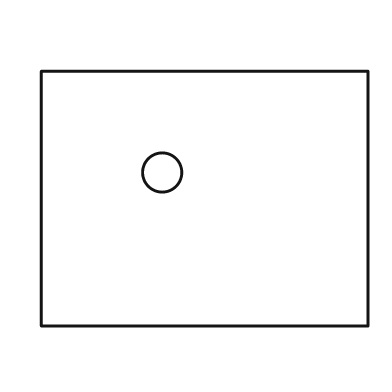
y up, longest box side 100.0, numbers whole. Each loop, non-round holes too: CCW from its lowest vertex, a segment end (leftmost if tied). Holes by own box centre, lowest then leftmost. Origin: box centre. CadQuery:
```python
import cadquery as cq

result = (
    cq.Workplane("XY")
    .moveTo(-50.0, -39.0)
    .lineTo(50.0, -39.0)
    .lineTo(50.0, 39.0)
    .lineTo(-50.0, 39.0)
    .close()
    .moveTo(-13.0, 8.0)
    .circle(6.0)
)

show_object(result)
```